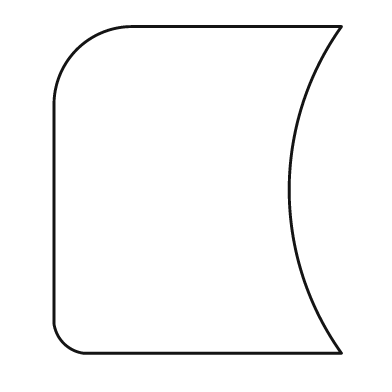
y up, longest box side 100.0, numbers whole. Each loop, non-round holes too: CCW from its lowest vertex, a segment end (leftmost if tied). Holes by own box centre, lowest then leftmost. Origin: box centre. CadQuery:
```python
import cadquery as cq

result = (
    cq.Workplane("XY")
    .moveTo(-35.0, -50.0)
    .lineTo(44.0, -50.0)
    .threePointArc((28.0, 0.0), (44.0, 50.0))
    .lineTo(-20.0, 50.0)
    .threePointArc((-37.0, 43.0), (-44.0, 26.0))
    .lineTo(-44.0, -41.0)
    .threePointArc((-41.0, -47.0), (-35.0, -50.0))
    .close()
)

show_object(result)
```